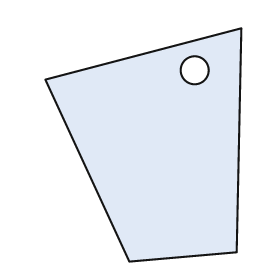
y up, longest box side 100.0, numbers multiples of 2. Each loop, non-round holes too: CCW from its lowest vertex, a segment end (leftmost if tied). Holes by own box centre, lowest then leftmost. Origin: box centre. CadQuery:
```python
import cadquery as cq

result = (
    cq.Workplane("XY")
    .moveTo(-6.0, -50.0)
    .lineTo(40.0, -46.0)
    .lineTo(42.0, 50.0)
    .lineTo(-42.0, 28.0)
    .close()
    .moveTo(22.0, 32.0)
    .circle(6.0)
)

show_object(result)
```